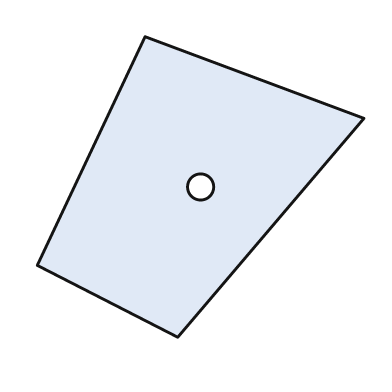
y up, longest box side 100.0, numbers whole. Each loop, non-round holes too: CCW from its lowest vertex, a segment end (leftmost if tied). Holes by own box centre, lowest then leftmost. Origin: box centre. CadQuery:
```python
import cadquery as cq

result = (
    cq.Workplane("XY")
    .moveTo(-7.0, -46.0)
    .lineTo(50.0, 21.0)
    .lineTo(-17.0, 46.0)
    .lineTo(-50.0, -24.0)
    .close()
    .moveTo(0.0, 0.0)
    .circle(4.0)
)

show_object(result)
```